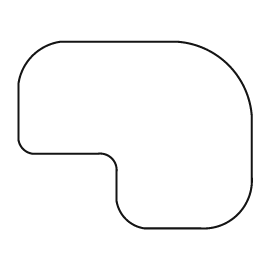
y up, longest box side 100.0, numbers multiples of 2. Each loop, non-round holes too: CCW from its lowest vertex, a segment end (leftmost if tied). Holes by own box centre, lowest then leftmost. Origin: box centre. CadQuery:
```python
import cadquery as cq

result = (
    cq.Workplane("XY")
    .moveTo(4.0, -40.0)
    .lineTo(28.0, -40.0)
    .threePointArc((44.0, -34.0), (50.0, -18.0))
    .lineTo(50.0, 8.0)
    .threePointArc((40.0, 30.0), (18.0, 40.0))
    .lineTo(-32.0, 40.0)
    .threePointArc((-44.0, 34.0), (-50.0, 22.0))
    .lineTo(-50.0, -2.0)
    .threePointArc((-48.0, -6.0), (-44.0, -8.0))
    .lineTo(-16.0, -8.0)
    .threePointArc((-10.0, -10.0), (-8.0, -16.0))
    .lineTo(-8.0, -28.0)
    .threePointArc((-4.0, -36.0), (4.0, -40.0))
    .close()
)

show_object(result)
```